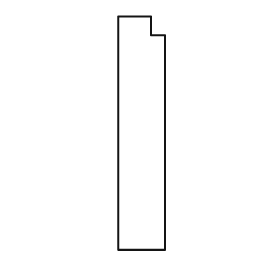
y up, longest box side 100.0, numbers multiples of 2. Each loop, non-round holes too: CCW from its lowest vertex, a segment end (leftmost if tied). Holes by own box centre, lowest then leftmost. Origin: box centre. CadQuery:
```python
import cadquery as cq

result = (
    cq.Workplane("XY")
    .moveTo(-10.0, -50.0)
    .lineTo(10.0, -50.0)
    .lineTo(10.0, 42.0)
    .lineTo(4.0, 42.0)
    .lineTo(4.0, 50.0)
    .lineTo(-10.0, 50.0)
    .close()
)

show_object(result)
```